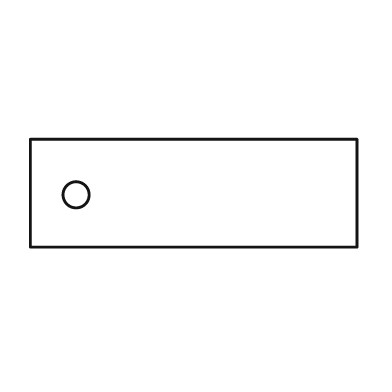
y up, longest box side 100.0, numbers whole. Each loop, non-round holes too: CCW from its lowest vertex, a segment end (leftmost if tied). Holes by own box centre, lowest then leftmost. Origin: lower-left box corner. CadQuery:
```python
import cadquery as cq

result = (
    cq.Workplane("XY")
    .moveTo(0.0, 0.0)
    .lineTo(100.0, 0.0)
    .lineTo(100.0, 33.0)
    .lineTo(0.0, 33.0)
    .close()
    .moveTo(14.0, 16.0)
    .circle(4.0)
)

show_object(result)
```